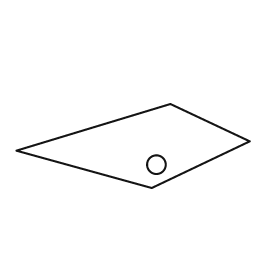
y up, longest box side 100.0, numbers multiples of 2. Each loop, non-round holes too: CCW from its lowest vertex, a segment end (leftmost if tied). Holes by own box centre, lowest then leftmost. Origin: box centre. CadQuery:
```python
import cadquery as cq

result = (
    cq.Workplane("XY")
    .moveTo(8.0, -18.0)
    .lineTo(50.0, 2.0)
    .lineTo(16.0, 18.0)
    .lineTo(-50.0, -2.0)
    .close()
    .moveTo(10.0, -8.0)
    .circle(4.0)
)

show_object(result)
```